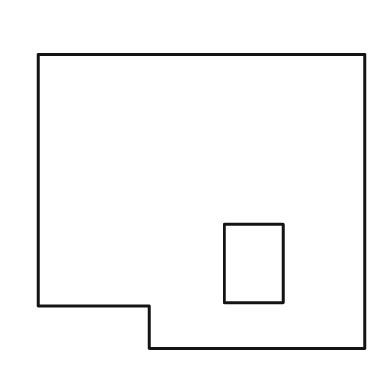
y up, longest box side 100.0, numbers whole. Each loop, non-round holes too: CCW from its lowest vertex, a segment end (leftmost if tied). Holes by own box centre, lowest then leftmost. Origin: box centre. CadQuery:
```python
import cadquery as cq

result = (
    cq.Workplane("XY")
    .moveTo(-16.0, -45.0)
    .lineTo(50.0, -45.0)
    .lineTo(50.0, 45.0)
    .lineTo(-50.0, 45.0)
    .lineTo(-50.0, -32.0)
    .lineTo(-16.0, -32.0)
    .close()
    .moveTo(7.0, -31.0)
    .lineTo(25.0, -31.0)
    .lineTo(25.0, -7.0)
    .lineTo(7.0, -7.0)
    .close()
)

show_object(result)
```